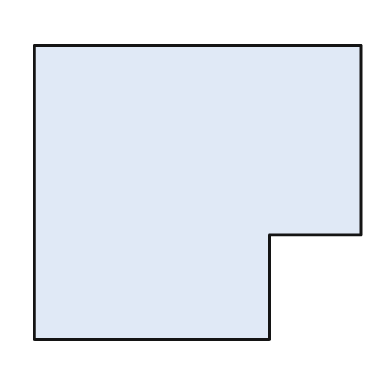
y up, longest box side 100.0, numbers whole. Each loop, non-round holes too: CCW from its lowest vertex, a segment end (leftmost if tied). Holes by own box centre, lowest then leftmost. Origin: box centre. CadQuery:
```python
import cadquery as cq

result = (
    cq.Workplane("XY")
    .moveTo(-50.0, -45.0)
    .lineTo(22.0, -45.0)
    .lineTo(22.0, -13.0)
    .lineTo(50.0, -13.0)
    .lineTo(50.0, 45.0)
    .lineTo(-50.0, 45.0)
    .close()
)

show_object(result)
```